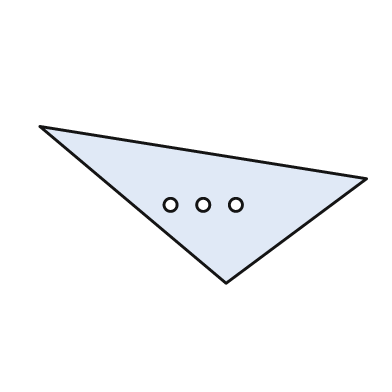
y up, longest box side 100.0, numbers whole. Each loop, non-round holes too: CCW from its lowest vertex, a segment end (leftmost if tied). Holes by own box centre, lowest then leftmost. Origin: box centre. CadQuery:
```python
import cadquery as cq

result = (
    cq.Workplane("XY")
    .moveTo(7.0, -24.0)
    .lineTo(50.0, 8.0)
    .lineTo(-50.0, 24.0)
    .close()
    .moveTo(-10.0, 0.0)
    .circle(2.0)
    .moveTo(0.0, 0.0)
    .circle(2.0)
    .moveTo(10.0, 0.0)
    .circle(2.0)
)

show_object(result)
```